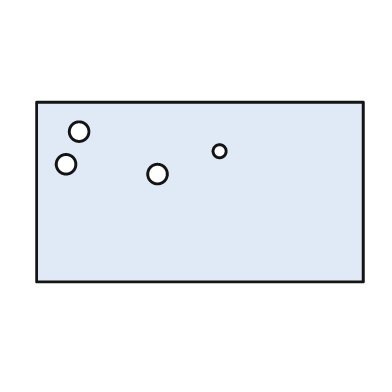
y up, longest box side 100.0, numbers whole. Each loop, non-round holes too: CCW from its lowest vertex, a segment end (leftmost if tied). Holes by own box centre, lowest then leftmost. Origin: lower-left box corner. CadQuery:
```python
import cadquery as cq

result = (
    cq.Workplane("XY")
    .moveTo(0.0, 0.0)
    .lineTo(100.0, 0.0)
    .lineTo(100.0, 55.0)
    .lineTo(0.0, 55.0)
    .close()
    .moveTo(37.0, 33.0)
    .circle(3.0)
    .moveTo(9.0, 36.0)
    .circle(3.0)
    .moveTo(56.0, 40.0)
    .circle(2.0)
    .moveTo(13.0, 46.0)
    .circle(3.0)
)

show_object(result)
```